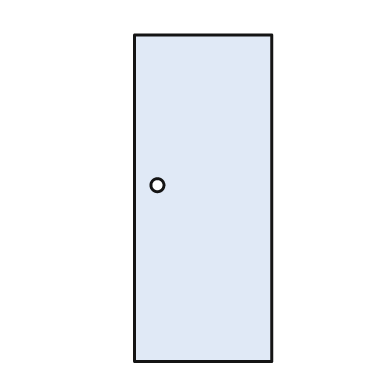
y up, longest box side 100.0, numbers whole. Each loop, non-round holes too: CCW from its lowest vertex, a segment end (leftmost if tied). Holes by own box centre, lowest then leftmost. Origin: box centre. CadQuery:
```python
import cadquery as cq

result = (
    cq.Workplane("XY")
    .moveTo(-21.0, -50.0)
    .lineTo(21.0, -50.0)
    .lineTo(21.0, 50.0)
    .lineTo(-21.0, 50.0)
    .close()
    .moveTo(-14.0, 4.0)
    .circle(2.0)
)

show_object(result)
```